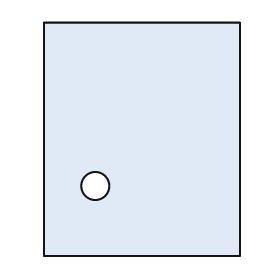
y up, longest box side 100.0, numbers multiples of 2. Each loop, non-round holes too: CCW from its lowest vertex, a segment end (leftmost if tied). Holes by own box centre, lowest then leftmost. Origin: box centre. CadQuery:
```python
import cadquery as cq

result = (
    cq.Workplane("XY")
    .moveTo(-42.0, -50.0)
    .lineTo(42.0, -50.0)
    .lineTo(42.0, 50.0)
    .lineTo(-42.0, 50.0)
    .close()
    .moveTo(-20.0, -20.0)
    .circle(6.0)
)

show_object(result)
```